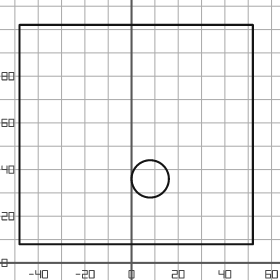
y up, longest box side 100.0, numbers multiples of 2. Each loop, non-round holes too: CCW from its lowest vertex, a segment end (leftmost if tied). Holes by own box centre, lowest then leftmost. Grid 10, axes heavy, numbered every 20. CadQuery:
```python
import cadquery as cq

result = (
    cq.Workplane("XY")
    .moveTo(-48.0, 8.0)
    .lineTo(52.0, 8.0)
    .lineTo(52.0, 102.0)
    .lineTo(-48.0, 102.0)
    .close()
    .moveTo(8.0, 36.0)
    .circle(8.0)
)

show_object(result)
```